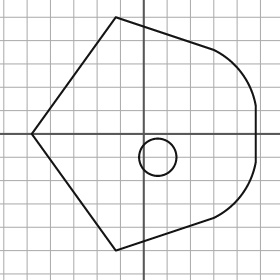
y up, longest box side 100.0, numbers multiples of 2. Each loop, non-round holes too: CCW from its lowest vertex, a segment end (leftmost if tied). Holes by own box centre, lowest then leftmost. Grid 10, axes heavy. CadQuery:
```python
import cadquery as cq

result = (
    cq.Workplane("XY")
    .moveTo(-12.0, -50.0)
    .lineTo(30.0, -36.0)
    .threePointArc((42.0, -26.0), (48.0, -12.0))
    .lineTo(48.0, 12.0)
    .threePointArc((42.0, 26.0), (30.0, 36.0))
    .lineTo(-12.0, 50.0)
    .lineTo(-48.0, 0.0)
    .close()
    .moveTo(6.0, -10.0)
    .circle(8.0)
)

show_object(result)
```